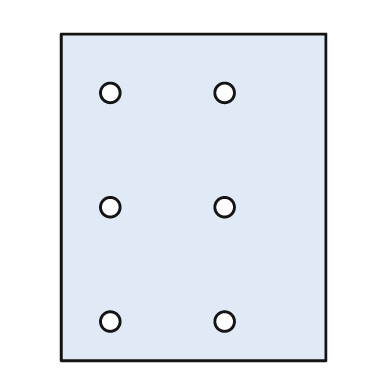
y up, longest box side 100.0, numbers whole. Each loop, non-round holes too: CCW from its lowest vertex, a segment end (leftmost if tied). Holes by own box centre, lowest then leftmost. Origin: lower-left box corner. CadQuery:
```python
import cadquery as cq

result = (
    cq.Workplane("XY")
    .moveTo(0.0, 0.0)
    .lineTo(81.0, 0.0)
    .lineTo(81.0, 100.0)
    .lineTo(0.0, 100.0)
    .close()
    .moveTo(15.0, 12.0)
    .circle(3.0)
    .moveTo(50.0, 12.0)
    .circle(3.0)
    .moveTo(15.0, 47.0)
    .circle(3.0)
    .moveTo(50.0, 47.0)
    .circle(3.0)
    .moveTo(15.0, 82.0)
    .circle(3.0)
    .moveTo(50.0, 82.0)
    .circle(3.0)
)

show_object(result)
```